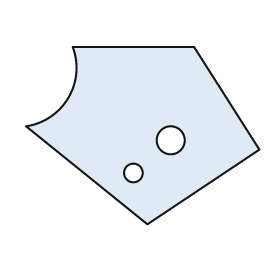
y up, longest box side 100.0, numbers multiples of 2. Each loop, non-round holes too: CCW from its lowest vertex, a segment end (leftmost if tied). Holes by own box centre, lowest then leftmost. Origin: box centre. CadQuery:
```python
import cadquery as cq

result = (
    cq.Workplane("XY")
    .moveTo(2.0, -38.0)
    .lineTo(50.0, -6.0)
    .lineTo(22.0, 38.0)
    .lineTo(-30.0, 38.0)
    .threePointArc((-32.0, 16.0), (-50.0, 4.0))
    .close()
    .moveTo(-4.0, -16.0)
    .circle(4.0)
    .moveTo(12.0, -2.0)
    .circle(6.0)
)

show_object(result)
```